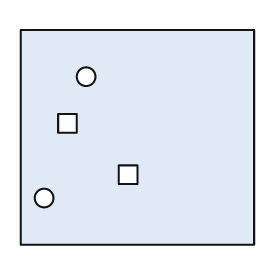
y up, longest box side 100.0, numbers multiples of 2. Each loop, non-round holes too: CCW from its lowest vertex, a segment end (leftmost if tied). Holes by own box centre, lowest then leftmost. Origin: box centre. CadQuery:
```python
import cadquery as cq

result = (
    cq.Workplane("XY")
    .moveTo(-50.0, -46.0)
    .lineTo(50.0, -46.0)
    .lineTo(50.0, 46.0)
    .lineTo(-50.0, 46.0)
    .close()
    .moveTo(-40.0, -26.0)
    .circle(4.0)
    .moveTo(-8.0, -20.0)
    .lineTo(0.0, -20.0)
    .lineTo(0.0, -12.0)
    .lineTo(-8.0, -12.0)
    .close()
    .moveTo(-34.0, 2.0)
    .lineTo(-26.0, 2.0)
    .lineTo(-26.0, 10.0)
    .lineTo(-34.0, 10.0)
    .close()
    .moveTo(-22.0, 26.0)
    .circle(4.0)
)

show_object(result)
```